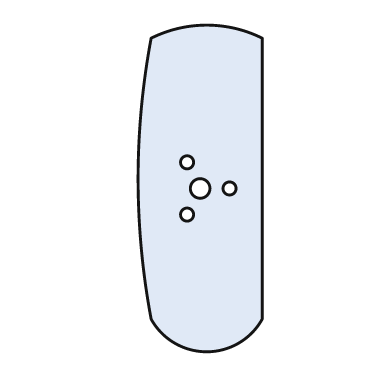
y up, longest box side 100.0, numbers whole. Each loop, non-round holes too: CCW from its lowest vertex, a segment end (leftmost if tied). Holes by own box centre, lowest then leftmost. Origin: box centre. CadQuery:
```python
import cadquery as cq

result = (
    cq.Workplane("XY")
    .moveTo(-15.0, -40.0)
    .threePointArc((2.0, -50.0), (19.0, -40.0))
    .lineTo(19.0, 46.0)
    .threePointArc((2.0, 50.0), (-15.0, 46.0))
    .threePointArc((-19.0, 3.0), (-15.0, -40.0))
    .close()
    .moveTo(-4.0, -8.0)
    .circle(2.0)
    .moveTo(0.0, 0.0)
    .circle(3.0)
    .moveTo(9.0, 0.0)
    .circle(2.0)
    .moveTo(-4.0, 8.0)
    .circle(2.0)
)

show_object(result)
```